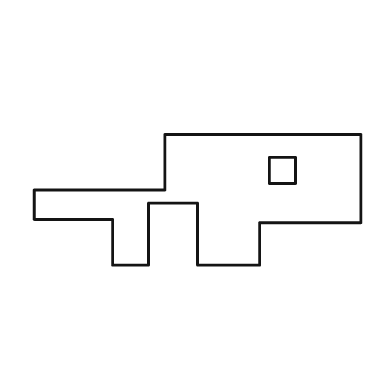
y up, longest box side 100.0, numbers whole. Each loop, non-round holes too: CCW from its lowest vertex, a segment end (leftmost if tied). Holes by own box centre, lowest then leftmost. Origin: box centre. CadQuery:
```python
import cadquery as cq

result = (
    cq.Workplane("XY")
    .moveTo(-26.0, -20.0)
    .lineTo(-15.0, -20.0)
    .lineTo(-15.0, -1.0)
    .lineTo(0.0, -1.0)
    .lineTo(0.0, -20.0)
    .lineTo(19.0, -20.0)
    .lineTo(19.0, -7.0)
    .lineTo(50.0, -7.0)
    .lineTo(50.0, 20.0)
    .lineTo(-10.0, 20.0)
    .lineTo(-10.0, 3.0)
    .lineTo(-50.0, 3.0)
    .lineTo(-50.0, -6.0)
    .lineTo(-26.0, -6.0)
    .close()
    .moveTo(22.0, 5.0)
    .lineTo(30.0, 5.0)
    .lineTo(30.0, 13.0)
    .lineTo(22.0, 13.0)
    .close()
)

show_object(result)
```